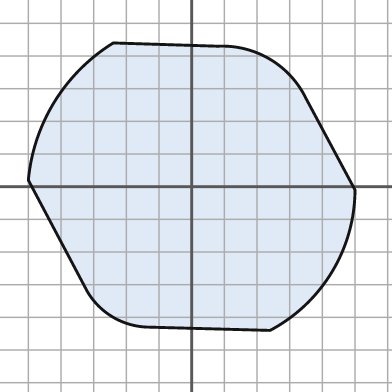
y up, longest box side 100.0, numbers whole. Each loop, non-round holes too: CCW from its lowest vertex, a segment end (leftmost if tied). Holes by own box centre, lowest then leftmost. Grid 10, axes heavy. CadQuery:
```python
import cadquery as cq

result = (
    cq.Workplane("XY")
    .moveTo(24.0, -44.0)
    .threePointArc((43.0, -26.0), (50.0, -1.0))
    .lineTo(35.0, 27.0)
    .threePointArc((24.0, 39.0), (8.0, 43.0))
    .lineTo(-24.0, 44.0)
    .threePointArc((-42.0, 26.0), (-50.0, 2.0))
    .lineTo(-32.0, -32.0)
    .threePointArc((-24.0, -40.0), (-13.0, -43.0))
    .close()
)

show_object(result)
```